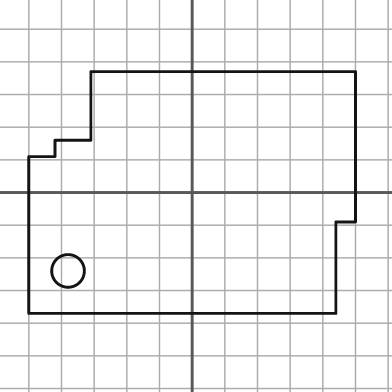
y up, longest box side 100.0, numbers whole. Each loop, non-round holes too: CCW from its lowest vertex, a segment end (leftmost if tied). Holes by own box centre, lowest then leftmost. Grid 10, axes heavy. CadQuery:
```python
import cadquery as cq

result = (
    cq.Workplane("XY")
    .moveTo(-50.0, -37.0)
    .lineTo(44.0, -37.0)
    .lineTo(44.0, -9.0)
    .lineTo(50.0, -9.0)
    .lineTo(50.0, 37.0)
    .lineTo(-31.0, 37.0)
    .lineTo(-31.0, 16.0)
    .lineTo(-42.0, 16.0)
    .lineTo(-42.0, 11.0)
    .lineTo(-50.0, 11.0)
    .close()
    .moveTo(-38.0, -24.0)
    .circle(5.0)
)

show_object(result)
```